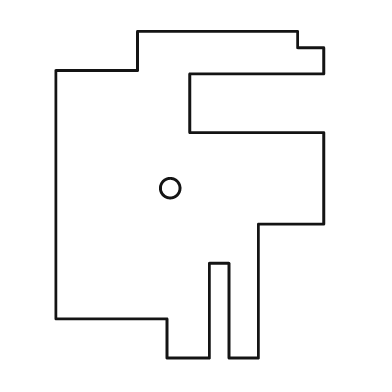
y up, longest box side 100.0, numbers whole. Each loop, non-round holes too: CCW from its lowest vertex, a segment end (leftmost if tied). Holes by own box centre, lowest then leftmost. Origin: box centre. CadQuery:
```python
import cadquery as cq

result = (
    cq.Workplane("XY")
    .moveTo(-7.0, -50.0)
    .lineTo(6.0, -50.0)
    .lineTo(6.0, -21.0)
    .lineTo(12.0, -21.0)
    .lineTo(12.0, -50.0)
    .lineTo(21.0, -50.0)
    .lineTo(21.0, -9.0)
    .lineTo(41.0, -9.0)
    .lineTo(41.0, 19.0)
    .lineTo(0.0, 19.0)
    .lineTo(0.0, 37.0)
    .lineTo(41.0, 37.0)
    .lineTo(41.0, 45.0)
    .lineTo(33.0, 45.0)
    .lineTo(33.0, 50.0)
    .lineTo(-16.0, 50.0)
    .lineTo(-16.0, 38.0)
    .lineTo(-41.0, 38.0)
    .lineTo(-41.0, -38.0)
    .lineTo(-7.0, -38.0)
    .close()
    .moveTo(-6.0, 2.0)
    .circle(3.0)
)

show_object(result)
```